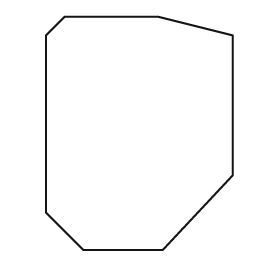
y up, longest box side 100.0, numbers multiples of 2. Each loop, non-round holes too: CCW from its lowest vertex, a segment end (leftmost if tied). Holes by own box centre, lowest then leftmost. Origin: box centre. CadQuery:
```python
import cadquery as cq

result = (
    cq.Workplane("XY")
    .moveTo(-24.0, -50.0)
    .lineTo(10.0, -50.0)
    .lineTo(40.0, -18.0)
    .lineTo(40.0, 42.0)
    .lineTo(8.0, 50.0)
    .lineTo(-32.0, 50.0)
    .lineTo(-40.0, 42.0)
    .lineTo(-40.0, -34.0)
    .close()
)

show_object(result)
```